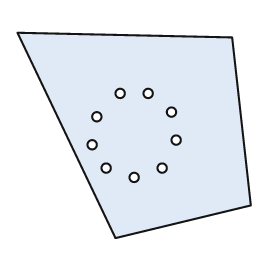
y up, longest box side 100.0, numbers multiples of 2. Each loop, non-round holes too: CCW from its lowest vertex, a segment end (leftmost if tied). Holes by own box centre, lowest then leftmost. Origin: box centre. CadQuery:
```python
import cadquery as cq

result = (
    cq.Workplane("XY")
    .moveTo(-8.0, -44.0)
    .lineTo(50.0, -30.0)
    .lineTo(42.0, 42.0)
    .lineTo(-50.0, 44.0)
    .close()
    .moveTo(0.0, -18.0)
    .circle(2.0)
    .moveTo(-12.0, -14.0)
    .circle(2.0)
    .moveTo(12.0, -14.0)
    .circle(2.0)
    .moveTo(-18.0, -4.0)
    .circle(2.0)
    .moveTo(18.0, -2.0)
    .circle(2.0)
    .moveTo(-16.0, 8.0)
    .circle(2.0)
    .moveTo(16.0, 10.0)
    .circle(2.0)
    .moveTo(-6.0, 18.0)
    .circle(2.0)
    .moveTo(6.0, 18.0)
    .circle(2.0)
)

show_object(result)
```